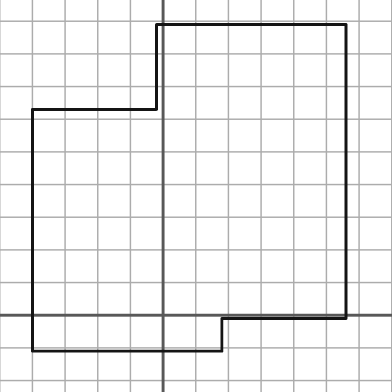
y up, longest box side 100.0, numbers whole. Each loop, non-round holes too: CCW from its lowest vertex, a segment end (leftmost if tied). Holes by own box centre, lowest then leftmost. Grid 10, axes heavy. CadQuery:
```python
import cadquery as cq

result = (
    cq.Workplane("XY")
    .moveTo(-40.0, -11.0)
    .lineTo(18.0, -11.0)
    .lineTo(18.0, -1.0)
    .lineTo(56.0, -1.0)
    .lineTo(56.0, 89.0)
    .lineTo(-2.0, 89.0)
    .lineTo(-2.0, 63.0)
    .lineTo(-40.0, 63.0)
    .close()
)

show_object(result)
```